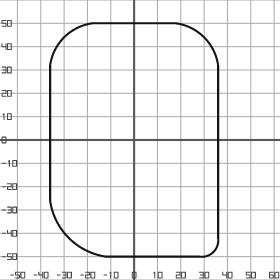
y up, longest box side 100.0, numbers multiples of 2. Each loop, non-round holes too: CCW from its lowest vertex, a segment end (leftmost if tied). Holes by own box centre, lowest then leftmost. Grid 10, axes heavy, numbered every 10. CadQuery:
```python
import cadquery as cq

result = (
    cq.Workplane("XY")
    .moveTo(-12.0, -50.0)
    .lineTo(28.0, -50.0)
    .threePointArc((34.0, -48.0), (36.0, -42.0))
    .lineTo(36.0, 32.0)
    .threePointArc((30.0, 44.0), (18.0, 50.0))
    .lineTo(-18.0, 50.0)
    .threePointArc((-30.0, 44.0), (-36.0, 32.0))
    .lineTo(-36.0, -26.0)
    .threePointArc((-28.0, -42.0), (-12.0, -50.0))
    .close()
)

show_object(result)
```